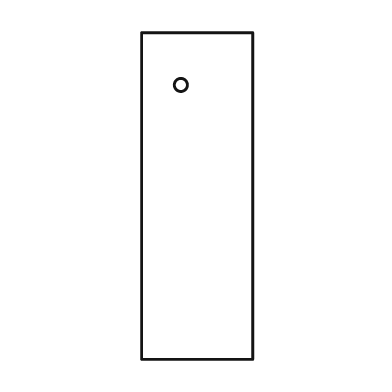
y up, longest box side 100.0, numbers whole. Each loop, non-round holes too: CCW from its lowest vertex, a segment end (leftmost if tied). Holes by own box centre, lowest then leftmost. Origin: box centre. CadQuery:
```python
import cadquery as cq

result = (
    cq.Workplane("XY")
    .moveTo(-17.0, -50.0)
    .lineTo(17.0, -50.0)
    .lineTo(17.0, 50.0)
    .lineTo(-17.0, 50.0)
    .close()
    .moveTo(-5.0, 34.0)
    .circle(2.0)
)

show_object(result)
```